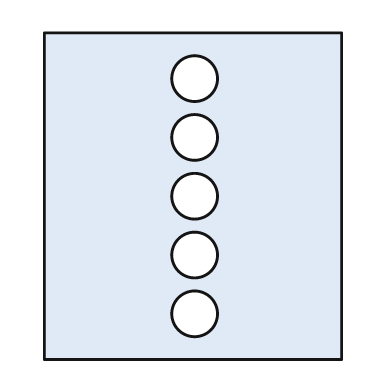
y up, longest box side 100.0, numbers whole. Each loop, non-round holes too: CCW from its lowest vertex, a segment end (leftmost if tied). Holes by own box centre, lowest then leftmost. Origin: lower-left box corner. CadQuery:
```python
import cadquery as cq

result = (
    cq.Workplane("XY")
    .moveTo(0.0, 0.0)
    .lineTo(91.0, 0.0)
    .lineTo(91.0, 100.0)
    .lineTo(0.0, 100.0)
    .close()
    .moveTo(46.0, 14.0)
    .circle(7.0)
    .moveTo(46.0, 32.0)
    .circle(7.0)
    .moveTo(46.0, 50.0)
    .circle(7.0)
    .moveTo(46.0, 68.0)
    .circle(7.0)
    .moveTo(46.0, 86.0)
    .circle(7.0)
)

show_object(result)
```